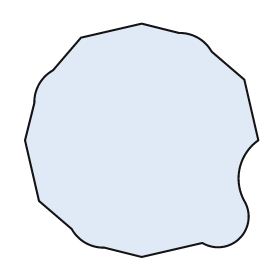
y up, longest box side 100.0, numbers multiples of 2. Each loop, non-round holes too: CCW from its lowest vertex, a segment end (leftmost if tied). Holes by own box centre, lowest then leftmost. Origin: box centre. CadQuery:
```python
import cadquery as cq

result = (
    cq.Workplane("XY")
    .moveTo(0.0, -50.0)
    .lineTo(26.0, -44.0)
    .threePointArc((42.0, -42.0), (44.0, -26.0))
    .threePointArc((42.0, -12.0), (50.0, 0.0))
    .lineTo(44.0, 26.0)
    .lineTo(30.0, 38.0)
    .threePointArc((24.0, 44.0), (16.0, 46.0))
    .lineTo(0.0, 50.0)
    .lineTo(-26.0, 44.0)
    .lineTo(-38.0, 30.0)
    .threePointArc((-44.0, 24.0), (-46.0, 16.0))
    .lineTo(-50.0, 0.0)
    .lineTo(-44.0, -26.0)
    .lineTo(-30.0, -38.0)
    .threePointArc((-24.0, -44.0), (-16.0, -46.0))
    .close()
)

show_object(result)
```